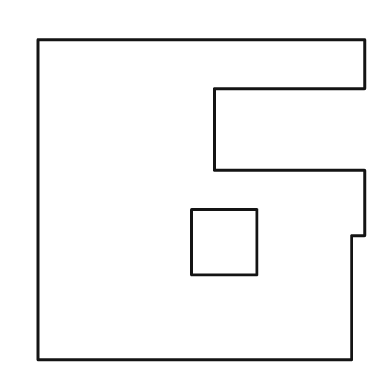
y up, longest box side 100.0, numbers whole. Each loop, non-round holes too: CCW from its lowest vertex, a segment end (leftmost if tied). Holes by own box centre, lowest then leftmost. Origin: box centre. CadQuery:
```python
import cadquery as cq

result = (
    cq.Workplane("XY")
    .moveTo(-50.0, -49.0)
    .lineTo(46.0, -49.0)
    .lineTo(46.0, -11.0)
    .lineTo(50.0, -11.0)
    .lineTo(50.0, 9.0)
    .lineTo(4.0, 9.0)
    .lineTo(4.0, 34.0)
    .lineTo(50.0, 34.0)
    .lineTo(50.0, 49.0)
    .lineTo(-50.0, 49.0)
    .close()
    .moveTo(-3.0, -23.0)
    .lineTo(17.0, -23.0)
    .lineTo(17.0, -3.0)
    .lineTo(-3.0, -3.0)
    .close()
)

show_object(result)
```